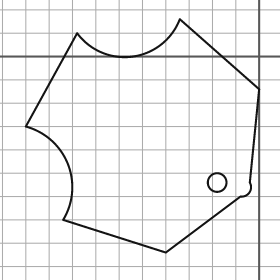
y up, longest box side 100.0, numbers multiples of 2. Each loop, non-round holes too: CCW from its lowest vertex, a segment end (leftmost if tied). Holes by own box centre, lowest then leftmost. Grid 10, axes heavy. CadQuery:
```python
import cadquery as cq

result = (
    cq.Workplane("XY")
    .moveTo(-40.0, -84.0)
    .lineTo(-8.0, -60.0)
    .threePointArc((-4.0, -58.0), (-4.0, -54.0))
    .lineTo(0.0, -14.0)
    .lineTo(-34.0, 16.0)
    .threePointArc((-54.0, 0.0), (-78.0, 10.0))
    .lineTo(-100.0, -30.0)
    .threePointArc((-82.0, -46.0), (-84.0, -70.0))
    .close()
    .moveTo(-18.0, -54.0)
    .circle(4.0)
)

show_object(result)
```